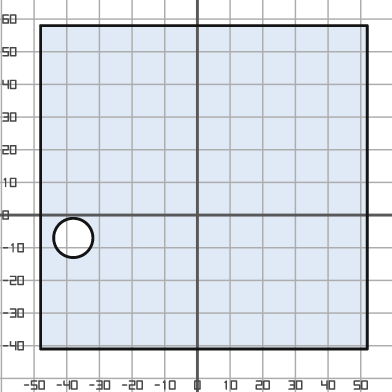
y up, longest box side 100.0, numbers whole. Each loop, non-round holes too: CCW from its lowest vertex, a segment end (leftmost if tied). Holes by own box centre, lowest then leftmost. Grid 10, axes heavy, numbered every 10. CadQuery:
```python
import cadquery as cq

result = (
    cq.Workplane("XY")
    .moveTo(-48.0, -41.0)
    .lineTo(52.0, -41.0)
    .lineTo(52.0, 58.0)
    .lineTo(-48.0, 58.0)
    .close()
    .moveTo(-38.0, -7.0)
    .circle(6.0)
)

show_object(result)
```